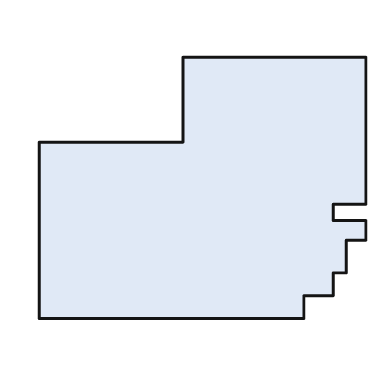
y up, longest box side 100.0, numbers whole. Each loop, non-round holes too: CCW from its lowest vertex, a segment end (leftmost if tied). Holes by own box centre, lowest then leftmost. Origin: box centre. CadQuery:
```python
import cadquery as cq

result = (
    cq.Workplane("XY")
    .moveTo(-50.0, -40.0)
    .lineTo(31.0, -40.0)
    .lineTo(31.0, -33.0)
    .lineTo(40.0, -33.0)
    .lineTo(40.0, -26.0)
    .lineTo(44.0, -26.0)
    .lineTo(44.0, -16.0)
    .lineTo(50.0, -16.0)
    .lineTo(50.0, -10.0)
    .lineTo(40.0, -10.0)
    .lineTo(40.0, -5.0)
    .lineTo(50.0, -5.0)
    .lineTo(50.0, 40.0)
    .lineTo(-6.0, 40.0)
    .lineTo(-6.0, 14.0)
    .lineTo(-50.0, 14.0)
    .close()
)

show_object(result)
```